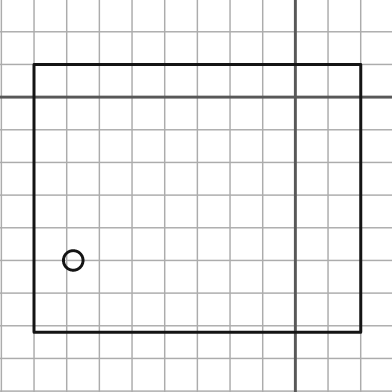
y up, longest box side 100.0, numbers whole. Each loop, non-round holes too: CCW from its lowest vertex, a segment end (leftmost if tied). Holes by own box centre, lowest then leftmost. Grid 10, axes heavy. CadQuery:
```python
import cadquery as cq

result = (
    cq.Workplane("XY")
    .moveTo(-80.0, -72.0)
    .lineTo(20.0, -72.0)
    .lineTo(20.0, 10.0)
    .lineTo(-80.0, 10.0)
    .close()
    .moveTo(-68.0, -50.0)
    .circle(3.0)
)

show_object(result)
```